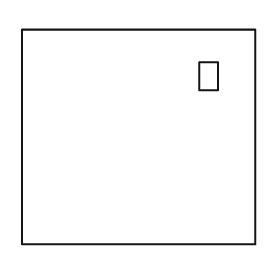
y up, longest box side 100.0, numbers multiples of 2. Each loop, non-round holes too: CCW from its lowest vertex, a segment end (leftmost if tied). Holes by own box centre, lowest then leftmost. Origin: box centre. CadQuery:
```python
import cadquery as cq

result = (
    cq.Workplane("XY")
    .moveTo(-50.0, -46.0)
    .lineTo(50.0, -46.0)
    .lineTo(50.0, 46.0)
    .lineTo(-50.0, 46.0)
    .close()
    .moveTo(26.0, 20.0)
    .lineTo(34.0, 20.0)
    .lineTo(34.0, 32.0)
    .lineTo(26.0, 32.0)
    .close()
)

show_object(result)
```